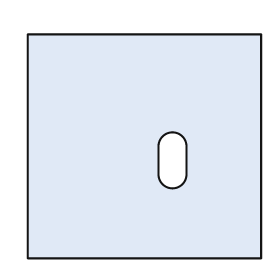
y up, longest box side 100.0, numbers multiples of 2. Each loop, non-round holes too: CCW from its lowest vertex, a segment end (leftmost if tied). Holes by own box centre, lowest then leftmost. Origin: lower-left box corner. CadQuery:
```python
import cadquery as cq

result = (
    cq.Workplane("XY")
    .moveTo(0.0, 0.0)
    .lineTo(100.0, 0.0)
    .lineTo(100.0, 96.0)
    .lineTo(0.0, 96.0)
    .close()
    .moveTo(56.0, 36.0)
    .threePointArc((62.0, 30.0), (68.0, 36.0))
    .lineTo(68.0, 48.0)
    .threePointArc((62.0, 54.0), (56.0, 48.0))
    .close()
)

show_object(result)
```